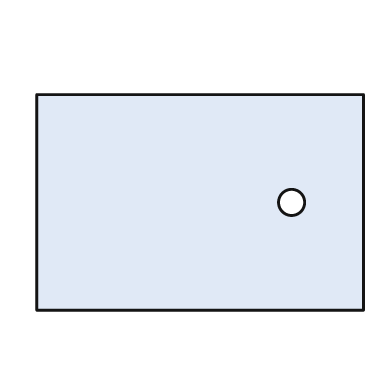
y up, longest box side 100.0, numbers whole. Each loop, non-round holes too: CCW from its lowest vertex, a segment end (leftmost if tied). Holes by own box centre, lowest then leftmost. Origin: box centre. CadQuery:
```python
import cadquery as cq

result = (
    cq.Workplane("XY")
    .moveTo(-50.0, -33.0)
    .lineTo(50.0, -33.0)
    .lineTo(50.0, 33.0)
    .lineTo(-50.0, 33.0)
    .close()
    .moveTo(28.0, 0.0)
    .circle(4.0)
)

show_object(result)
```